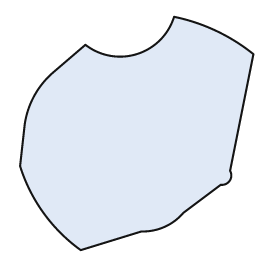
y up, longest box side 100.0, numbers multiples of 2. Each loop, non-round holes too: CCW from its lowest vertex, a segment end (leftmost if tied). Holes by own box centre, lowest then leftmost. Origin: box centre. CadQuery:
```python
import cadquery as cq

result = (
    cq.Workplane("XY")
    .moveTo(-24.0, -50.0)
    .lineTo(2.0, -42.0)
    .threePointArc((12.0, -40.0), (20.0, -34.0))
    .lineTo(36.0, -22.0)
    .threePointArc((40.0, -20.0), (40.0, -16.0))
    .lineTo(50.0, 34.0)
    .threePointArc((34.0, 44.0), (16.0, 50.0))
    .threePointArc((0.0, 34.0), (-22.0, 38.0))
    .lineTo(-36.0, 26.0)
    .threePointArc((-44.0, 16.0), (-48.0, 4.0))
    .lineTo(-50.0, -14.0)
    .threePointArc((-40.0, -34.0), (-24.0, -50.0))
    .close()
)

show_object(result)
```